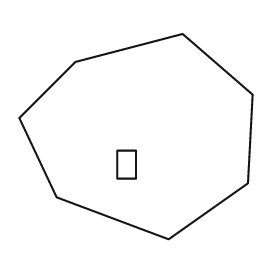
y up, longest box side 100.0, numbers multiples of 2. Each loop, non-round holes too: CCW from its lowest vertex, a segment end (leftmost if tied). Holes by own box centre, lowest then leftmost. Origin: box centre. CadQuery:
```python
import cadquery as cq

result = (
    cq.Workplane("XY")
    .moveTo(14.0, -44.0)
    .lineTo(48.0, -20.0)
    .lineTo(50.0, 18.0)
    .lineTo(20.0, 44.0)
    .lineTo(-26.0, 32.0)
    .lineTo(-50.0, 8.0)
    .lineTo(-34.0, -26.0)
    .close()
    .moveTo(-8.0, -18.0)
    .lineTo(0.0, -18.0)
    .lineTo(0.0, -6.0)
    .lineTo(-8.0, -6.0)
    .close()
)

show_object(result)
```